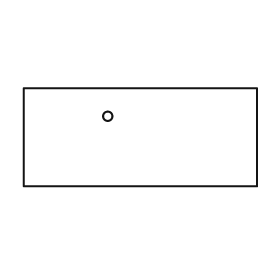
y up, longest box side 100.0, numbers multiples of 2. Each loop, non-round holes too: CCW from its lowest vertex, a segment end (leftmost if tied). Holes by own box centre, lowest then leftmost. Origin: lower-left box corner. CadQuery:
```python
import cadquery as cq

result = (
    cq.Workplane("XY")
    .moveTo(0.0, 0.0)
    .lineTo(100.0, 0.0)
    .lineTo(100.0, 42.0)
    .lineTo(0.0, 42.0)
    .close()
    .moveTo(36.0, 30.0)
    .circle(2.0)
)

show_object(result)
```